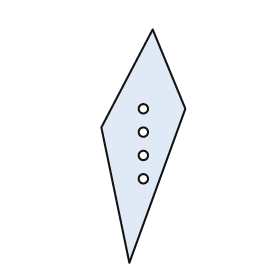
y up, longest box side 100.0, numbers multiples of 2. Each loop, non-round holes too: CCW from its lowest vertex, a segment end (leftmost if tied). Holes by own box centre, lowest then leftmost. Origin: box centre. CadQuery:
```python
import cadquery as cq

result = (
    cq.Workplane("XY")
    .moveTo(-6.0, -50.0)
    .lineTo(18.0, 16.0)
    .lineTo(4.0, 50.0)
    .lineTo(-18.0, 8.0)
    .close()
    .moveTo(0.0, -14.0)
    .circle(2.0)
    .moveTo(0.0, -4.0)
    .circle(2.0)
    .moveTo(0.0, 6.0)
    .circle(2.0)
    .moveTo(0.0, 16.0)
    .circle(2.0)
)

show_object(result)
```